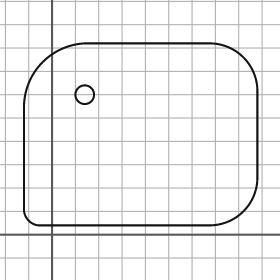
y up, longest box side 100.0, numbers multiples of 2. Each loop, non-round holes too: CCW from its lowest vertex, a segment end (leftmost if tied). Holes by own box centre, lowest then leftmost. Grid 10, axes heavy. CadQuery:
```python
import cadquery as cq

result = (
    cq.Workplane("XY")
    .moveTo(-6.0, 4.0)
    .lineTo(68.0, 4.0)
    .threePointArc((82.0, 10.0), (88.0, 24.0))
    .lineTo(88.0, 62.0)
    .threePointArc((82.0, 76.0), (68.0, 82.0))
    .lineTo(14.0, 82.0)
    .threePointArc((-4.0, 74.0), (-12.0, 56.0))
    .lineTo(-12.0, 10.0)
    .threePointArc((-10.0, 6.0), (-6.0, 4.0))
    .close()
    .moveTo(14.0, 60.0)
    .circle(4.0)
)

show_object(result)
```